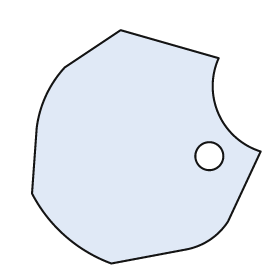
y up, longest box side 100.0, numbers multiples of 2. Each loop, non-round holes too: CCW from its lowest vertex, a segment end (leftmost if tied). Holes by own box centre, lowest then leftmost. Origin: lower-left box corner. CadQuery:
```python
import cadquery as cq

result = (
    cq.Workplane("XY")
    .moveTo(34.0, 0.0)
    .lineTo(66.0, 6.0)
    .threePointArc((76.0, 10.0), (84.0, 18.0))
    .lineTo(98.0, 48.0)
    .threePointArc((80.0, 64.0), (80.0, 88.0))
    .lineTo(38.0, 100.0)
    .lineTo(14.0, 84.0)
    .threePointArc((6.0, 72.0), (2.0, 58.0))
    .lineTo(0.0, 30.0)
    .threePointArc((14.0, 12.0), (34.0, 0.0))
    .close()
    .moveTo(76.0, 46.0)
    .circle(6.0)
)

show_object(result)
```